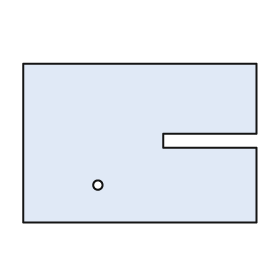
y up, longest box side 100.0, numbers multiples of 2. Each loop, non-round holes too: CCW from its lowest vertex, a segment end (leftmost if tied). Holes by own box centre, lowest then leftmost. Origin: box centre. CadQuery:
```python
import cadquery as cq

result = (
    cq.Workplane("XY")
    .moveTo(-50.0, -34.0)
    .lineTo(50.0, -34.0)
    .lineTo(50.0, -2.0)
    .lineTo(10.0, -2.0)
    .lineTo(10.0, 4.0)
    .lineTo(50.0, 4.0)
    .lineTo(50.0, 34.0)
    .lineTo(-50.0, 34.0)
    .close()
    .moveTo(-18.0, -18.0)
    .circle(2.0)
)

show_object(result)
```